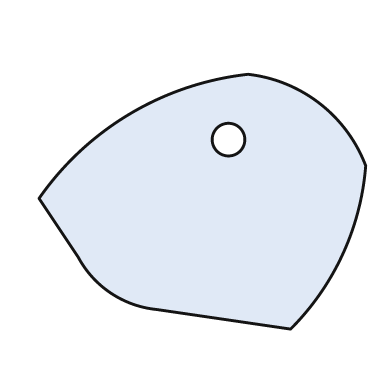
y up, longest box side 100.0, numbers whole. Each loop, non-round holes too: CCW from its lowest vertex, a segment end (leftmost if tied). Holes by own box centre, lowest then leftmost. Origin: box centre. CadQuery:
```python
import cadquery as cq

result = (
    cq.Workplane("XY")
    .moveTo(27.0, -39.0)
    .threePointArc((43.0, -16.0), (50.0, 11.0))
    .threePointArc((36.0, 30.0), (14.0, 39.0))
    .threePointArc((-22.0, 27.0), (-50.0, 1.0))
    .lineTo(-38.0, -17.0)
    .threePointArc((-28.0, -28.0), (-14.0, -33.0))
    .close()
    .moveTo(8.0, 19.0)
    .circle(5.0)
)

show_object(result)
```